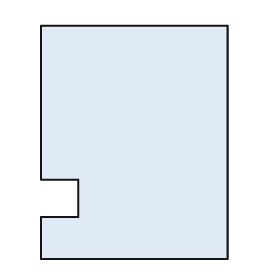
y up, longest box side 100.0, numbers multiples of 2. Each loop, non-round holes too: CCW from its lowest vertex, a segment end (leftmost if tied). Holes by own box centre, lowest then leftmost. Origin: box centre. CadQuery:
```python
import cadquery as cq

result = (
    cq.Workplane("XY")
    .moveTo(-40.0, -50.0)
    .lineTo(40.0, -50.0)
    .lineTo(40.0, 50.0)
    .lineTo(-40.0, 50.0)
    .lineTo(-40.0, -16.0)
    .lineTo(-24.0, -16.0)
    .lineTo(-24.0, -32.0)
    .lineTo(-40.0, -32.0)
    .close()
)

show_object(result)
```